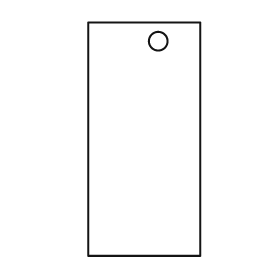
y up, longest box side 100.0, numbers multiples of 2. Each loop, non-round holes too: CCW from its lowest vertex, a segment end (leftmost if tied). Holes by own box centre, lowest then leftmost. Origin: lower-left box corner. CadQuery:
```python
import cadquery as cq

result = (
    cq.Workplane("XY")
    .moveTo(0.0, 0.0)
    .lineTo(48.0, 0.0)
    .lineTo(48.0, 100.0)
    .lineTo(0.0, 100.0)
    .close()
    .moveTo(30.0, 92.0)
    .circle(4.0)
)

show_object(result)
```